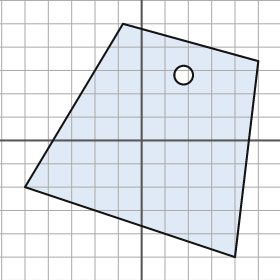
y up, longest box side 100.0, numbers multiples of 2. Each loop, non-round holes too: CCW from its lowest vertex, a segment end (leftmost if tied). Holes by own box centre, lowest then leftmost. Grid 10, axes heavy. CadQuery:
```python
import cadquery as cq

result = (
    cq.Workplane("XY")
    .moveTo(40.0, -50.0)
    .lineTo(50.0, 34.0)
    .lineTo(-8.0, 50.0)
    .lineTo(-50.0, -20.0)
    .close()
    .moveTo(18.0, 28.0)
    .circle(4.0)
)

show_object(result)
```